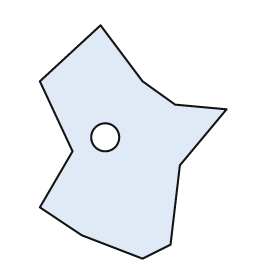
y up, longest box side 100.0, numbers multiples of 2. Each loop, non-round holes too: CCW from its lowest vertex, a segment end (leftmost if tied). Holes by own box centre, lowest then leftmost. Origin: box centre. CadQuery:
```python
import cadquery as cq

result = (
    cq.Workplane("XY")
    .moveTo(4.0, -50.0)
    .lineTo(16.0, -44.0)
    .lineTo(20.0, -10.0)
    .lineTo(40.0, 14.0)
    .lineTo(18.0, 16.0)
    .lineTo(4.0, 26.0)
    .lineTo(-14.0, 50.0)
    .lineTo(-40.0, 26.0)
    .lineTo(-26.0, -4.0)
    .lineTo(-40.0, -28.0)
    .lineTo(-22.0, -40.0)
    .close()
    .moveTo(-12.0, 2.0)
    .circle(6.0)
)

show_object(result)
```